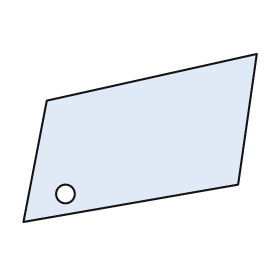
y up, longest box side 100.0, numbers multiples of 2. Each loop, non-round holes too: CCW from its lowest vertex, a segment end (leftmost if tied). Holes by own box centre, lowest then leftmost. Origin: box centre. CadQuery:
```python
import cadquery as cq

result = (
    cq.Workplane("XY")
    .moveTo(-50.0, -36.0)
    .lineTo(42.0, -20.0)
    .lineTo(50.0, 36.0)
    .lineTo(-40.0, 16.0)
    .close()
    .moveTo(-32.0, -24.0)
    .circle(4.0)
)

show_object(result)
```